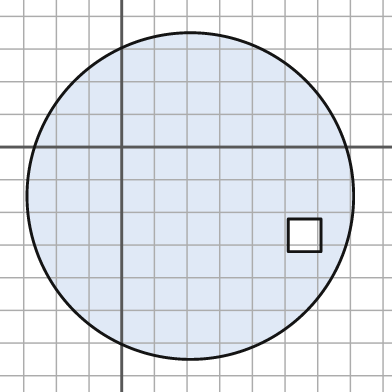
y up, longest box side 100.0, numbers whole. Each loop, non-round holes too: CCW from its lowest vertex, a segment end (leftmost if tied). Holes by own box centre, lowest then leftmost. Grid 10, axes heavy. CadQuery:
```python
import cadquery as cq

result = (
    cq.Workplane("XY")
    .moveTo(21.0, -15.0)
    .circle(50.0)
    .moveTo(51.0, -32.0)
    .lineTo(61.0, -32.0)
    .lineTo(61.0, -22.0)
    .lineTo(51.0, -22.0)
    .close()
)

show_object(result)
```